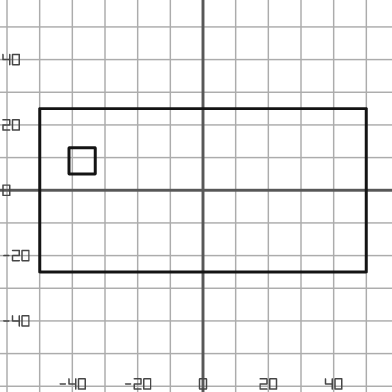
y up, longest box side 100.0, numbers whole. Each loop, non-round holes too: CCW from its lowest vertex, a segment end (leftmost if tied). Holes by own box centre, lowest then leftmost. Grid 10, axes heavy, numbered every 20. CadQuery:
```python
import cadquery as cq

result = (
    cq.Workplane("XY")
    .moveTo(-50.0, -25.0)
    .lineTo(50.0, -25.0)
    .lineTo(50.0, 25.0)
    .lineTo(-50.0, 25.0)
    .close()
    .moveTo(-41.0, 5.0)
    .lineTo(-33.0, 5.0)
    .lineTo(-33.0, 13.0)
    .lineTo(-41.0, 13.0)
    .close()
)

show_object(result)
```